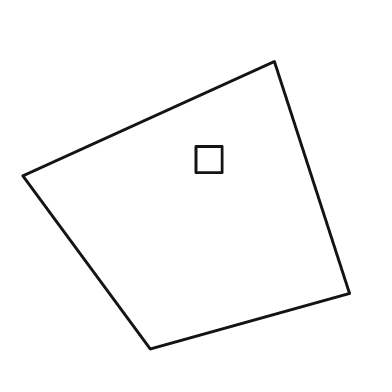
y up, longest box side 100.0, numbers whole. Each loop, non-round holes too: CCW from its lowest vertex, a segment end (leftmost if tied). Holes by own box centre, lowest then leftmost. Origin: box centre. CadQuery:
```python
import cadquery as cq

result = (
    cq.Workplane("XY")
    .moveTo(-11.0, -44.0)
    .lineTo(50.0, -27.0)
    .lineTo(27.0, 44.0)
    .lineTo(-50.0, 9.0)
    .close()
    .moveTo(3.0, 10.0)
    .lineTo(11.0, 10.0)
    .lineTo(11.0, 18.0)
    .lineTo(3.0, 18.0)
    .close()
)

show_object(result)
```